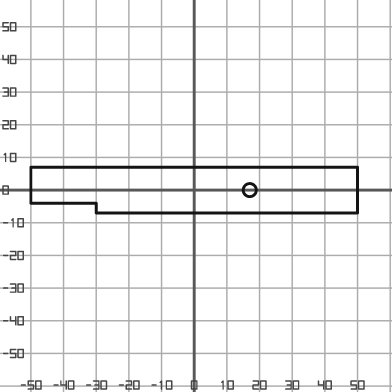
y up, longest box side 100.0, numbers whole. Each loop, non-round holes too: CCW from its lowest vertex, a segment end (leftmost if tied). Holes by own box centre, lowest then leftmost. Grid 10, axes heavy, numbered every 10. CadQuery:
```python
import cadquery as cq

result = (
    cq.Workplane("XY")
    .moveTo(-30.0, -7.0)
    .lineTo(50.0, -7.0)
    .lineTo(50.0, 7.0)
    .lineTo(-50.0, 7.0)
    .lineTo(-50.0, -4.0)
    .lineTo(-30.0, -4.0)
    .close()
    .moveTo(17.0, 0.0)
    .circle(2.0)
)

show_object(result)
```